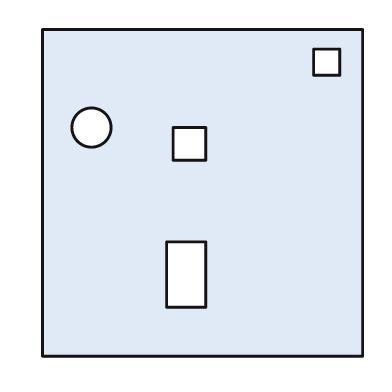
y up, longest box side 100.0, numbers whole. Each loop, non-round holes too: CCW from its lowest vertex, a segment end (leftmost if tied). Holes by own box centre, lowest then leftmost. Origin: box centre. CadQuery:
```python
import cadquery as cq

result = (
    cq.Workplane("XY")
    .moveTo(-49.0, -50.0)
    .lineTo(49.0, -50.0)
    .lineTo(49.0, 50.0)
    .lineTo(-49.0, 50.0)
    .close()
    .moveTo(-11.0, -35.0)
    .lineTo(1.0, -35.0)
    .lineTo(1.0, -15.0)
    .lineTo(-11.0, -15.0)
    .close()
    .moveTo(-9.0, 10.0)
    .lineTo(1.0, 10.0)
    .lineTo(1.0, 20.0)
    .lineTo(-9.0, 20.0)
    .close()
    .moveTo(-34.0, 20.0)
    .circle(6.0)
    .moveTo(34.0, 36.0)
    .lineTo(42.0, 36.0)
    .lineTo(42.0, 44.0)
    .lineTo(34.0, 44.0)
    .close()
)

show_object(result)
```